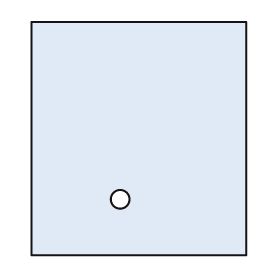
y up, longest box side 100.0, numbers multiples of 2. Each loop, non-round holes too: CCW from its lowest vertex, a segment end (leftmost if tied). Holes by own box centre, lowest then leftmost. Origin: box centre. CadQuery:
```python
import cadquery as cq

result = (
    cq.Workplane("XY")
    .moveTo(-46.0, -50.0)
    .lineTo(46.0, -50.0)
    .lineTo(46.0, 50.0)
    .lineTo(-46.0, 50.0)
    .close()
    .moveTo(-8.0, -26.0)
    .circle(4.0)
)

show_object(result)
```